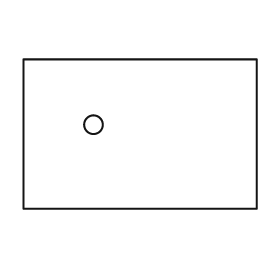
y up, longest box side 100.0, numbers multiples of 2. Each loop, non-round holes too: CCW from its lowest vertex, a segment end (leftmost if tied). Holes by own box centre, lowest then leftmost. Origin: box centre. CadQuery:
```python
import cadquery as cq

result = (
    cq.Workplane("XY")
    .moveTo(-50.0, -32.0)
    .lineTo(50.0, -32.0)
    .lineTo(50.0, 32.0)
    .lineTo(-50.0, 32.0)
    .close()
    .moveTo(-20.0, 4.0)
    .circle(4.0)
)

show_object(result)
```